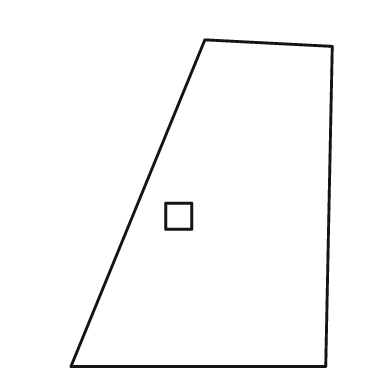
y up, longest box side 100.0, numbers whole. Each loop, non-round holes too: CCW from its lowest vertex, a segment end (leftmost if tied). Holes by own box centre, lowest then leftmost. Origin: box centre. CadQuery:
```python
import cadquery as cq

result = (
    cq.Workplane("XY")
    .moveTo(-40.0, -50.0)
    .lineTo(38.0, -50.0)
    .lineTo(40.0, 48.0)
    .lineTo(1.0, 50.0)
    .close()
    .moveTo(-11.0, -8.0)
    .lineTo(-3.0, -8.0)
    .lineTo(-3.0, 0.0)
    .lineTo(-11.0, 0.0)
    .close()
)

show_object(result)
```